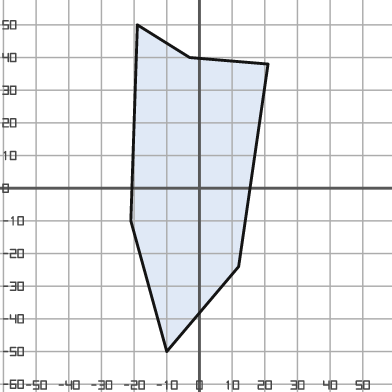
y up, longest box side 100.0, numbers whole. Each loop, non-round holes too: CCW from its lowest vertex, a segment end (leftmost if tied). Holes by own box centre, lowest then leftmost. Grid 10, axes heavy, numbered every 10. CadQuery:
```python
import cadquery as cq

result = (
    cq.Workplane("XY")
    .moveTo(-10.0, -50.0)
    .lineTo(12.0, -24.0)
    .lineTo(21.0, 38.0)
    .lineTo(-3.0, 40.0)
    .lineTo(-19.0, 50.0)
    .lineTo(-21.0, -10.0)
    .close()
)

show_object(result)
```